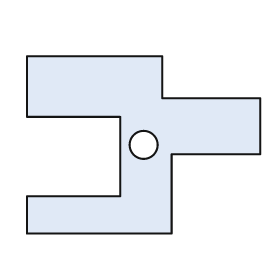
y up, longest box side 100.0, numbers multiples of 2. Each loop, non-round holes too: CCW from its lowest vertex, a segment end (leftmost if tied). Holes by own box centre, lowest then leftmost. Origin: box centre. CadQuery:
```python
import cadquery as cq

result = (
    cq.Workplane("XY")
    .moveTo(-50.0, -38.0)
    .lineTo(12.0, -38.0)
    .lineTo(12.0, -4.0)
    .lineTo(50.0, -4.0)
    .lineTo(50.0, 20.0)
    .lineTo(8.0, 20.0)
    .lineTo(8.0, 38.0)
    .lineTo(-50.0, 38.0)
    .lineTo(-50.0, 12.0)
    .lineTo(-10.0, 12.0)
    .lineTo(-10.0, -22.0)
    .lineTo(-50.0, -22.0)
    .close()
    .moveTo(0.0, 0.0)
    .circle(6.0)
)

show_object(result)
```